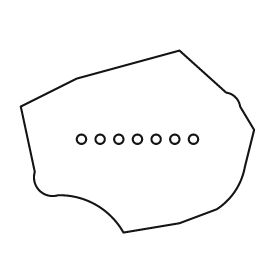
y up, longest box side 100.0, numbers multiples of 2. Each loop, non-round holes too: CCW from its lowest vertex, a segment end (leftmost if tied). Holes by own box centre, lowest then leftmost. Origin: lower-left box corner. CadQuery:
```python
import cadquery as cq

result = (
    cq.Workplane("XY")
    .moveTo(44.0, 0.0)
    .lineTo(68.0, 4.0)
    .lineTo(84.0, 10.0)
    .threePointArc((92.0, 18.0), (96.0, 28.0))
    .lineTo(100.0, 44.0)
    .lineTo(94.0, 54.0)
    .threePointArc((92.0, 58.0), (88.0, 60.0))
    .lineTo(68.0, 78.0)
    .lineTo(24.0, 66.0)
    .lineTo(0.0, 54.0)
    .lineTo(6.0, 26.0)
    .threePointArc((8.0, 18.0), (16.0, 16.0))
    .threePointArc((32.0, 12.0), (44.0, 0.0))
    .close()
    .moveTo(26.0, 40.0)
    .circle(2.0)
    .moveTo(34.0, 40.0)
    .circle(2.0)
    .moveTo(42.0, 40.0)
    .circle(2.0)
    .moveTo(50.0, 40.0)
    .circle(2.0)
    .moveTo(58.0, 40.0)
    .circle(2.0)
    .moveTo(66.0, 40.0)
    .circle(2.0)
    .moveTo(74.0, 40.0)
    .circle(2.0)
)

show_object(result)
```